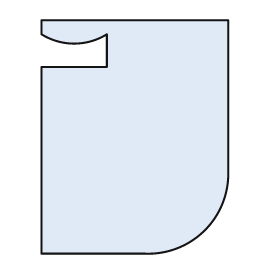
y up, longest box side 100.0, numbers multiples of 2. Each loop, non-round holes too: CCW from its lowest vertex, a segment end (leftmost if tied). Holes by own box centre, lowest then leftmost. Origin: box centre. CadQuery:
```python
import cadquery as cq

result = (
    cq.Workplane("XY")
    .moveTo(-40.0, -50.0)
    .lineTo(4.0, -50.0)
    .threePointArc((30.0, -40.0), (40.0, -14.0))
    .lineTo(40.0, 50.0)
    .lineTo(-40.0, 50.0)
    .lineTo(-40.0, 44.0)
    .threePointArc((-26.0, 40.0), (-12.0, 44.0))
    .lineTo(-12.0, 30.0)
    .lineTo(-40.0, 30.0)
    .close()
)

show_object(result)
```